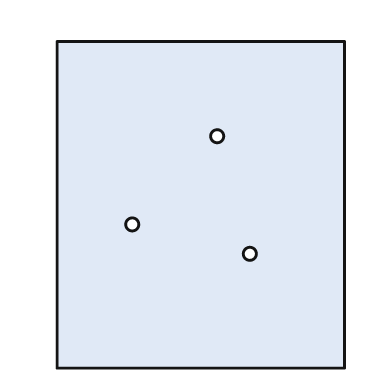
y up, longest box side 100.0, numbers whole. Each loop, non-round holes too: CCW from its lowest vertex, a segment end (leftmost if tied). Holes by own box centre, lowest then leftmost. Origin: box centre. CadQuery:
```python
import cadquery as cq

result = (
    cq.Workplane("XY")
    .moveTo(-44.0, -50.0)
    .lineTo(44.0, -50.0)
    .lineTo(44.0, 50.0)
    .lineTo(-44.0, 50.0)
    .close()
    .moveTo(15.0, -15.0)
    .circle(2.0)
    .moveTo(-21.0, -6.0)
    .circle(2.0)
    .moveTo(5.0, 21.0)
    .circle(2.0)
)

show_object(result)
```